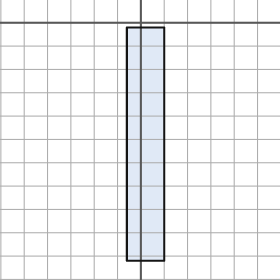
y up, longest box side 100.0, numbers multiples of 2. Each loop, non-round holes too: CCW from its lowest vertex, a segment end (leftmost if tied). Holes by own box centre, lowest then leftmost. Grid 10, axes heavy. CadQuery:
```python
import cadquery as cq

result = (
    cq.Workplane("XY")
    .moveTo(-6.0, -102.0)
    .lineTo(10.0, -102.0)
    .lineTo(10.0, -2.0)
    .lineTo(-6.0, -2.0)
    .close()
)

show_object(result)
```